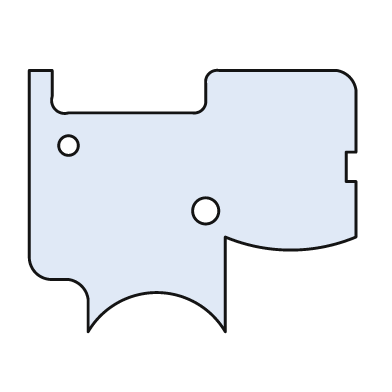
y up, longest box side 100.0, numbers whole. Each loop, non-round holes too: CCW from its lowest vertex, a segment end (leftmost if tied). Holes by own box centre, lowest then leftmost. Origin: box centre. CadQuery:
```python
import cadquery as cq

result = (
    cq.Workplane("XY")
    .moveTo(-32.0, -40.0)
    .threePointArc((-11.0, -28.0), (10.0, -40.0))
    .lineTo(10.0, -11.0)
    .threePointArc((30.0, -15.0), (50.0, -11.0))
    .lineTo(50.0, 6.0)
    .lineTo(47.0, 6.0)
    .lineTo(47.0, 15.0)
    .lineTo(50.0, 15.0)
    .lineTo(50.0, 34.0)
    .threePointArc((48.0, 38.0), (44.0, 40.0))
    .lineTo(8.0, 40.0)
    .threePointArc((5.0, 39.0), (4.0, 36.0))
    .lineTo(4.0, 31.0)
    .threePointArc((3.0, 28.0), (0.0, 27.0))
    .lineTo(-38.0, 27.0)
    .threePointArc((-42.0, 28.0), (-43.0, 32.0))
    .lineTo(-43.0, 40.0)
    .lineTo(-50.0, 40.0)
    .lineTo(-50.0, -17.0)
    .threePointArc((-48.0, -22.0), (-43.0, -24.0))
    .lineTo(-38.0, -24.0)
    .threePointArc((-34.0, -26.0), (-32.0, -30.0))
    .close()
    .moveTo(4.0, -3.0)
    .circle(4.0)
    .moveTo(-38.0, 17.0)
    .circle(3.0)
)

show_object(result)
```